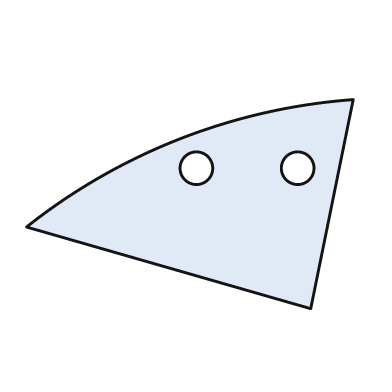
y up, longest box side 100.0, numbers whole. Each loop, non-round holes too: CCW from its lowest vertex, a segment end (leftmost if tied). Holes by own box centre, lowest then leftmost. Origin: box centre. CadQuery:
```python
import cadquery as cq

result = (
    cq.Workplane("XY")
    .moveTo(37.0, -32.0)
    .lineTo(50.0, 32.0)
    .threePointArc((-3.0, 20.0), (-50.0, -7.0))
    .close()
    .moveTo(2.0, 11.0)
    .circle(5.0)
    .moveTo(33.0, 11.0)
    .circle(5.0)
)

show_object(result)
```